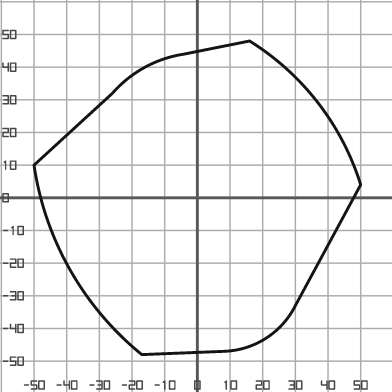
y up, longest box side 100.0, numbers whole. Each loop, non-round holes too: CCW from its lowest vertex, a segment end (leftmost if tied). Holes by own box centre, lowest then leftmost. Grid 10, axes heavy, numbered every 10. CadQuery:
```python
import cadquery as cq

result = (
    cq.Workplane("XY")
    .moveTo(-17.0, -48.0)
    .lineTo(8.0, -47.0)
    .threePointArc((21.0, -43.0), (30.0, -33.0))
    .lineTo(50.0, 4.0)
    .threePointArc((37.0, 29.0), (16.0, 48.0))
    .lineTo(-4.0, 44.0)
    .threePointArc((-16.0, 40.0), (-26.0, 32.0))
    .lineTo(-50.0, 10.0)
    .threePointArc((-39.0, -22.0), (-17.0, -48.0))
    .close()
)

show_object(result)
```